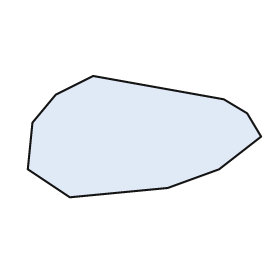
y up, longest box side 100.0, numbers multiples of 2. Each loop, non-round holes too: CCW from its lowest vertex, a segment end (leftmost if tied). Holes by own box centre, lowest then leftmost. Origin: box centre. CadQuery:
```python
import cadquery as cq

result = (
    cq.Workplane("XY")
    .moveTo(-32.0, -26.0)
    .lineTo(10.0, -22.0)
    .lineTo(32.0, -14.0)
    .lineTo(50.0, 0.0)
    .lineTo(44.0, 10.0)
    .lineTo(34.0, 16.0)
    .lineTo(-22.0, 26.0)
    .lineTo(-38.0, 18.0)
    .lineTo(-48.0, 6.0)
    .lineTo(-50.0, -14.0)
    .close()
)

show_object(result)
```